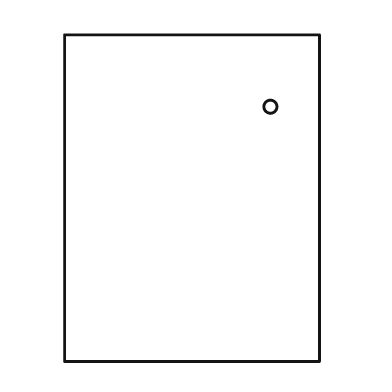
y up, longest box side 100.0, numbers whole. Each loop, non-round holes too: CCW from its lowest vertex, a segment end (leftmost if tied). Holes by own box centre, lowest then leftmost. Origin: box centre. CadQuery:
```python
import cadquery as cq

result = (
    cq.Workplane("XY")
    .moveTo(-39.0, -50.0)
    .lineTo(39.0, -50.0)
    .lineTo(39.0, 50.0)
    .lineTo(-39.0, 50.0)
    .close()
    .moveTo(24.0, 28.0)
    .circle(2.0)
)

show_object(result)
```